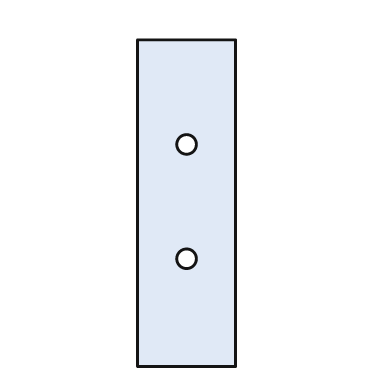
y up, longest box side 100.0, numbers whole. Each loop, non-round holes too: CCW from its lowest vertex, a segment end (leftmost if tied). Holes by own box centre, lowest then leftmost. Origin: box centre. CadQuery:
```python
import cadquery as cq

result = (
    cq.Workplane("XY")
    .moveTo(-15.0, -50.0)
    .lineTo(15.0, -50.0)
    .lineTo(15.0, 50.0)
    .lineTo(-15.0, 50.0)
    .close()
    .moveTo(0.0, -17.0)
    .circle(3.0)
    .moveTo(0.0, 18.0)
    .circle(3.0)
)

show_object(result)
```